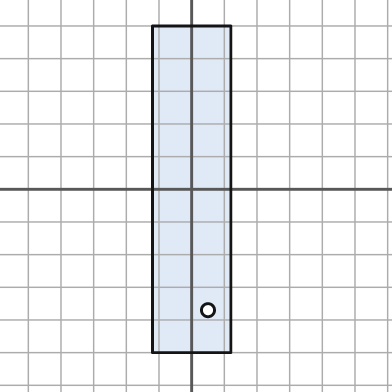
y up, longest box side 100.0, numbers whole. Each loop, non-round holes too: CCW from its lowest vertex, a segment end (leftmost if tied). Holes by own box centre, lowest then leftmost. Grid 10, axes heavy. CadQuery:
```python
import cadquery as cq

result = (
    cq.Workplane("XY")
    .moveTo(-12.0, -50.0)
    .lineTo(12.0, -50.0)
    .lineTo(12.0, 50.0)
    .lineTo(-12.0, 50.0)
    .close()
    .moveTo(5.0, -37.0)
    .circle(2.0)
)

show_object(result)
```